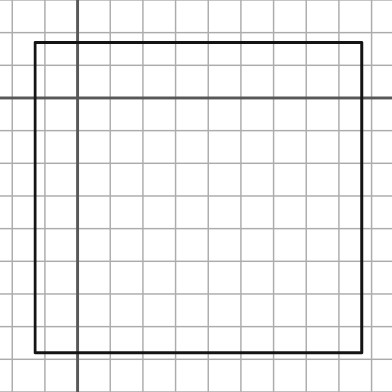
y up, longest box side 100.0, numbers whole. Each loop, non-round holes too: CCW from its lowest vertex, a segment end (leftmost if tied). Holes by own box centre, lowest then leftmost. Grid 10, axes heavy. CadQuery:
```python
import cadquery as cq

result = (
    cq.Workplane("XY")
    .moveTo(-13.0, -78.0)
    .lineTo(87.0, -78.0)
    .lineTo(87.0, 17.0)
    .lineTo(-13.0, 17.0)
    .close()
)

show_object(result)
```